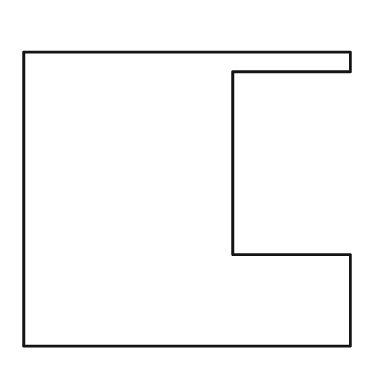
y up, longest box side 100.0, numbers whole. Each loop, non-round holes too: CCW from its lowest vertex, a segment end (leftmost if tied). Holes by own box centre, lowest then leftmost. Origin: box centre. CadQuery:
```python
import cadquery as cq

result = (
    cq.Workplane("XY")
    .moveTo(-50.0, -45.0)
    .lineTo(50.0, -45.0)
    .lineTo(50.0, -17.0)
    .lineTo(14.0, -17.0)
    .lineTo(14.0, 39.0)
    .lineTo(50.0, 39.0)
    .lineTo(50.0, 45.0)
    .lineTo(-50.0, 45.0)
    .close()
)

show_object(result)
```